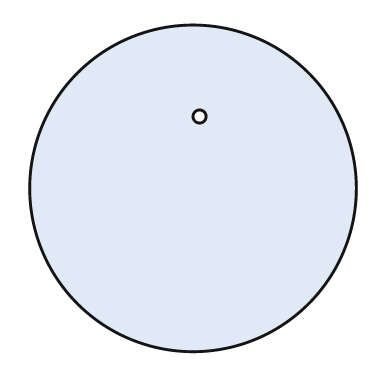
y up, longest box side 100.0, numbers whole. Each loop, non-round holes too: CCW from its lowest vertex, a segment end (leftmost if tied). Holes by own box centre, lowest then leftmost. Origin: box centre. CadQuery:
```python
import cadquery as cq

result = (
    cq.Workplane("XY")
    .moveTo(0.0, 0.0)
    .circle(50.0)
    .moveTo(2.0, 22.0)
    .circle(2.0)
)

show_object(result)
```